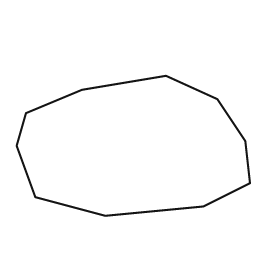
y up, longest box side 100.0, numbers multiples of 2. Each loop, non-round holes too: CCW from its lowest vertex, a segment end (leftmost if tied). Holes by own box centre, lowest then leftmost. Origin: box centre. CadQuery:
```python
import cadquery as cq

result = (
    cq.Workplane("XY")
    .moveTo(-12.0, -30.0)
    .lineTo(30.0, -26.0)
    .lineTo(50.0, -16.0)
    .lineTo(48.0, 2.0)
    .lineTo(36.0, 20.0)
    .lineTo(14.0, 30.0)
    .lineTo(-22.0, 24.0)
    .lineTo(-46.0, 14.0)
    .lineTo(-50.0, 0.0)
    .lineTo(-42.0, -22.0)
    .close()
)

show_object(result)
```